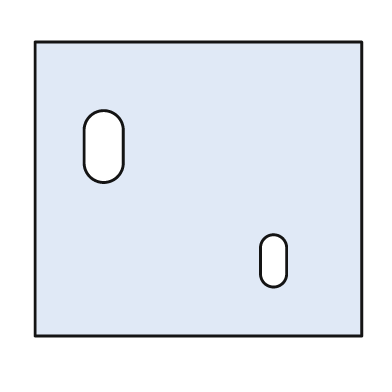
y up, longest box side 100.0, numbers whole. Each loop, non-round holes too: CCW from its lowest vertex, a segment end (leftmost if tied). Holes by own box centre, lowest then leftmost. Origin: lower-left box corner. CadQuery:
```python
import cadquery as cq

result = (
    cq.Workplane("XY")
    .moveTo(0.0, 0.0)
    .lineTo(100.0, 0.0)
    .lineTo(100.0, 90.0)
    .lineTo(0.0, 90.0)
    .close()
    .moveTo(69.0, 19.0)
    .threePointArc((73.0, 15.0), (77.0, 19.0))
    .lineTo(77.0, 27.0)
    .threePointArc((73.0, 31.0), (69.0, 27.0))
    .close()
    .moveTo(15.0, 53.0)
    .threePointArc((21.0, 47.0), (27.0, 53.0))
    .lineTo(27.0, 63.0)
    .threePointArc((21.0, 69.0), (15.0, 63.0))
    .close()
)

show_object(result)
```